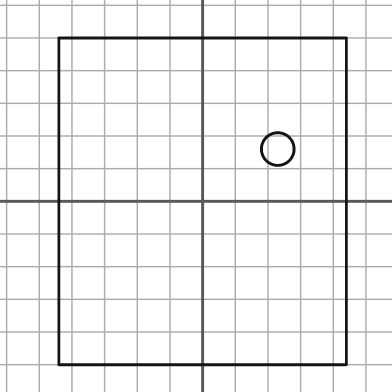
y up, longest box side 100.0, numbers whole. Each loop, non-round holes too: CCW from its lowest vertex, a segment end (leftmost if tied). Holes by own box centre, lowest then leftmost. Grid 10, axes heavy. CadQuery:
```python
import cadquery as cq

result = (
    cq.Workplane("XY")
    .moveTo(-44.0, -50.0)
    .lineTo(44.0, -50.0)
    .lineTo(44.0, 50.0)
    .lineTo(-44.0, 50.0)
    .close()
    .moveTo(23.0, 16.0)
    .circle(5.0)
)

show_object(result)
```